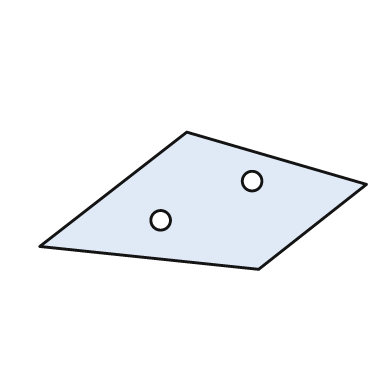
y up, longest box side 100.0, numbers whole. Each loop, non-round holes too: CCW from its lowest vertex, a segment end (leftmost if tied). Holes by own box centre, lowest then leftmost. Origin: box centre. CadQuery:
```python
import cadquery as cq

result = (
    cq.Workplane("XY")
    .moveTo(17.0, -21.0)
    .lineTo(50.0, 5.0)
    .lineTo(-5.0, 21.0)
    .lineTo(-50.0, -14.0)
    .close()
    .moveTo(-13.0, -6.0)
    .circle(3.0)
    .moveTo(15.0, 6.0)
    .circle(3.0)
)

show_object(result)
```